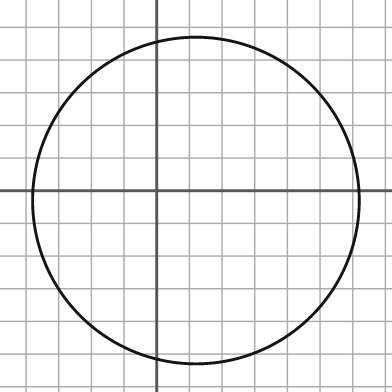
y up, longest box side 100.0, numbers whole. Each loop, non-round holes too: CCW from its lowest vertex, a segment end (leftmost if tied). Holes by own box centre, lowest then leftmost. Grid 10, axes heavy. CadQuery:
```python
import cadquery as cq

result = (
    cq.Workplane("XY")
    .moveTo(12.0, -3.0)
    .circle(50.0)
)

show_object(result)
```